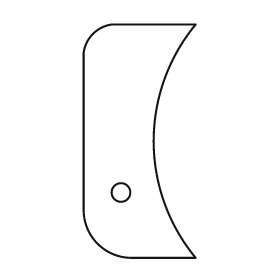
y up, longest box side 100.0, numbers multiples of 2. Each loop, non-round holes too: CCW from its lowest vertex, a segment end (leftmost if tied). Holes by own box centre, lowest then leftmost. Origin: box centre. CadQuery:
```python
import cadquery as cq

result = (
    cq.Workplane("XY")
    .moveTo(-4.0, -50.0)
    .lineTo(24.0, -50.0)
    .threePointArc((6.0, 0.0), (24.0, 50.0))
    .lineTo(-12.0, 50.0)
    .threePointArc((-20.0, 46.0), (-24.0, 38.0))
    .lineTo(-24.0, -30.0)
    .threePointArc((-18.0, -44.0), (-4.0, -50.0))
    .close()
    .moveTo(-8.0, -22.0)
    .circle(4.0)
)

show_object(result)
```